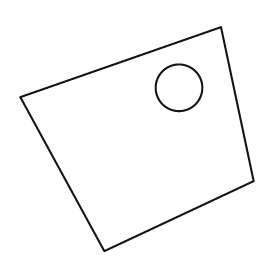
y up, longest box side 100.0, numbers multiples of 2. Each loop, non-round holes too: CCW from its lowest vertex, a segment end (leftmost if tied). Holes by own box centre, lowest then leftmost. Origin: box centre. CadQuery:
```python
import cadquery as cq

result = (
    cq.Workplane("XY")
    .moveTo(-14.0, -48.0)
    .lineTo(50.0, -18.0)
    .lineTo(36.0, 48.0)
    .lineTo(-50.0, 18.0)
    .close()
    .moveTo(18.0, 22.0)
    .circle(10.0)
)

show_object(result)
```